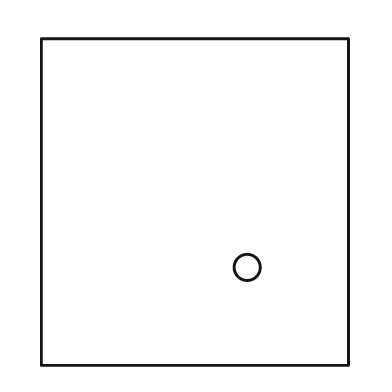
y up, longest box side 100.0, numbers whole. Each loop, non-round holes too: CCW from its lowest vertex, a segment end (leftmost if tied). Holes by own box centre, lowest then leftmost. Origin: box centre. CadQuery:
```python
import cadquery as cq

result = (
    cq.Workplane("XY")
    .moveTo(-47.0, -50.0)
    .lineTo(47.0, -50.0)
    .lineTo(47.0, 50.0)
    .lineTo(-47.0, 50.0)
    .close()
    .moveTo(16.0, -20.0)
    .circle(4.0)
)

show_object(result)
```